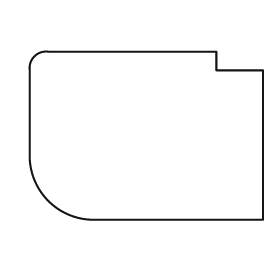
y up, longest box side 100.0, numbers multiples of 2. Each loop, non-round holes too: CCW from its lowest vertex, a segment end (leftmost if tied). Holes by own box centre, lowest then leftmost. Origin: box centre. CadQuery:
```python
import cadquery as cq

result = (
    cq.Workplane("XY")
    .moveTo(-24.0, -36.0)
    .lineTo(50.0, -36.0)
    .lineTo(50.0, 28.0)
    .lineTo(30.0, 28.0)
    .lineTo(30.0, 36.0)
    .lineTo(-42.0, 36.0)
    .threePointArc((-48.0, 34.0), (-50.0, 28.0))
    .lineTo(-50.0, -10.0)
    .threePointArc((-42.0, -28.0), (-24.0, -36.0))
    .close()
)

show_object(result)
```